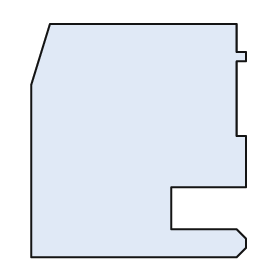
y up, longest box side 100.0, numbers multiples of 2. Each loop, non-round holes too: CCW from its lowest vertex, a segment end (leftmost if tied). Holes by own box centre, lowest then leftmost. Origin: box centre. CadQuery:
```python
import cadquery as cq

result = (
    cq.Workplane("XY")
    .moveTo(-46.0, -50.0)
    .lineTo(42.0, -50.0)
    .lineTo(46.0, -46.0)
    .lineTo(46.0, -42.0)
    .lineTo(42.0, -38.0)
    .lineTo(14.0, -38.0)
    .lineTo(14.0, -20.0)
    .lineTo(46.0, -20.0)
    .lineTo(46.0, 2.0)
    .lineTo(42.0, 2.0)
    .lineTo(42.0, 34.0)
    .lineTo(46.0, 34.0)
    .lineTo(46.0, 38.0)
    .lineTo(42.0, 38.0)
    .lineTo(42.0, 50.0)
    .lineTo(-38.0, 50.0)
    .lineTo(-46.0, 24.0)
    .close()
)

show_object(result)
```